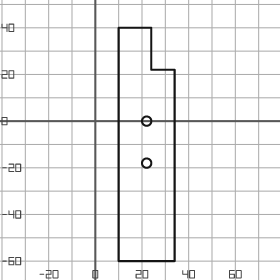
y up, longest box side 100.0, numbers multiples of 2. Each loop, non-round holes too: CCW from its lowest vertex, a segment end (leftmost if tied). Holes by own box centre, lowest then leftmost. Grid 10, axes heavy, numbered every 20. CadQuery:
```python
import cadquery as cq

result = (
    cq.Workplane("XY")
    .moveTo(10.0, -60.0)
    .lineTo(34.0, -60.0)
    .lineTo(34.0, 22.0)
    .lineTo(24.0, 22.0)
    .lineTo(24.0, 40.0)
    .lineTo(10.0, 40.0)
    .close()
    .moveTo(22.0, -18.0)
    .circle(2.0)
    .moveTo(22.0, 0.0)
    .circle(2.0)
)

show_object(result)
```